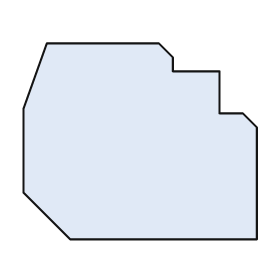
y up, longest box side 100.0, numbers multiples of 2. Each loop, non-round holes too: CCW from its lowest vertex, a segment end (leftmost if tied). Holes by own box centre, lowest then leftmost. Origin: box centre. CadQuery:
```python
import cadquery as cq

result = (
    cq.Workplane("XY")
    .moveTo(-30.0, -42.0)
    .lineTo(50.0, -42.0)
    .lineTo(50.0, 6.0)
    .lineTo(44.0, 12.0)
    .lineTo(34.0, 12.0)
    .lineTo(34.0, 30.0)
    .lineTo(14.0, 30.0)
    .lineTo(14.0, 36.0)
    .lineTo(8.0, 42.0)
    .lineTo(-40.0, 42.0)
    .lineTo(-50.0, 14.0)
    .lineTo(-50.0, -22.0)
    .close()
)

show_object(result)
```